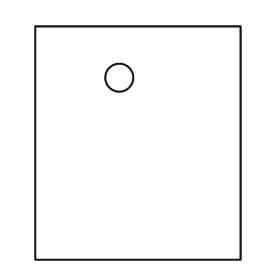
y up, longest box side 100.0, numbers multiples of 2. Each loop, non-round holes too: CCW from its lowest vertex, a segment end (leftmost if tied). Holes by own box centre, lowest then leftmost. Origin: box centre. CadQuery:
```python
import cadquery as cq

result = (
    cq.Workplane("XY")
    .moveTo(-44.0, -50.0)
    .lineTo(44.0, -50.0)
    .lineTo(44.0, 50.0)
    .lineTo(-44.0, 50.0)
    .close()
    .moveTo(-8.0, 28.0)
    .circle(6.0)
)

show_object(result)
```